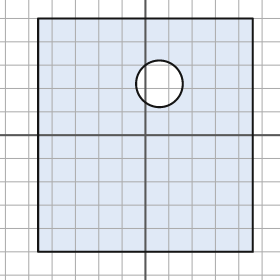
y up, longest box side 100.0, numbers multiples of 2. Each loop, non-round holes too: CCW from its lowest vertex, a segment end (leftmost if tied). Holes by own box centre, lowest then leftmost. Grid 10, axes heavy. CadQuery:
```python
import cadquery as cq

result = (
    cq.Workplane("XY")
    .moveTo(-46.0, -50.0)
    .lineTo(46.0, -50.0)
    .lineTo(46.0, 50.0)
    .lineTo(-46.0, 50.0)
    .close()
    .moveTo(6.0, 22.0)
    .circle(10.0)
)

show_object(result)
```